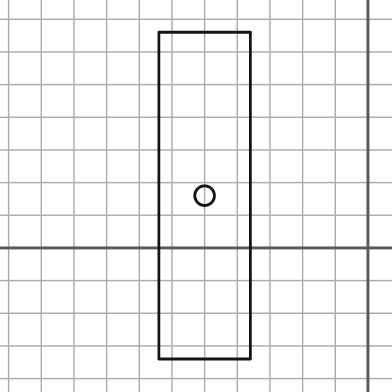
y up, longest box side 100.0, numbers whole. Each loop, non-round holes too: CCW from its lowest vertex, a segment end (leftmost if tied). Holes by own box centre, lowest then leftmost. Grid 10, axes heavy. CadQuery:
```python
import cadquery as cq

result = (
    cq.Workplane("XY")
    .moveTo(-64.0, -34.0)
    .lineTo(-36.0, -34.0)
    .lineTo(-36.0, 66.0)
    .lineTo(-64.0, 66.0)
    .close()
    .moveTo(-50.0, 16.0)
    .circle(3.0)
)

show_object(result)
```